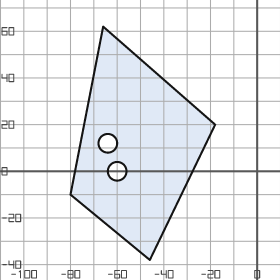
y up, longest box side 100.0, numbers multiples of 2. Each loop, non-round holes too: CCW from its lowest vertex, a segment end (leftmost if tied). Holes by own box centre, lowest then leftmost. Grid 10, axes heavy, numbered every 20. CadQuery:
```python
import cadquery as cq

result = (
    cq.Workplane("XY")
    .moveTo(-46.0, -38.0)
    .lineTo(-18.0, 20.0)
    .lineTo(-66.0, 62.0)
    .lineTo(-80.0, -10.0)
    .close()
    .moveTo(-60.0, 0.0)
    .circle(4.0)
    .moveTo(-64.0, 12.0)
    .circle(4.0)
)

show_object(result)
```